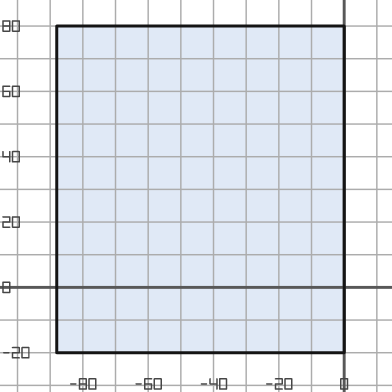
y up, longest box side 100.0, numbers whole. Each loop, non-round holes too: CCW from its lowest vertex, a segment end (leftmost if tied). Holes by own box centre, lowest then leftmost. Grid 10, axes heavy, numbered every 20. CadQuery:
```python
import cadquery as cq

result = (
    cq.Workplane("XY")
    .moveTo(-88.0, -20.0)
    .lineTo(0.0, -20.0)
    .lineTo(0.0, 80.0)
    .lineTo(-88.0, 80.0)
    .close()
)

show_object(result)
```